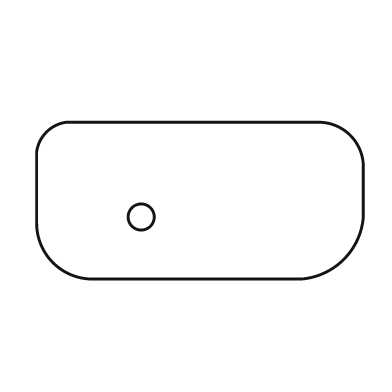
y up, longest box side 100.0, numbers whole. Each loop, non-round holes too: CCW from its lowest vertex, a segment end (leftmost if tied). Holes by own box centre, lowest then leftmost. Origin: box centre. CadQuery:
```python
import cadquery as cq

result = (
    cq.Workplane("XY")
    .moveTo(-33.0, -24.0)
    .lineTo(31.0, -24.0)
    .threePointArc((44.0, -18.0), (50.0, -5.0))
    .lineTo(50.0, 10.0)
    .threePointArc((46.0, 20.0), (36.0, 24.0))
    .lineTo(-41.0, 24.0)
    .threePointArc((-47.0, 21.0), (-50.0, 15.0))
    .lineTo(-50.0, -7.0)
    .threePointArc((-45.0, -19.0), (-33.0, -24.0))
    .close()
    .moveTo(-18.0, -5.0)
    .circle(4.0)
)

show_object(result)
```